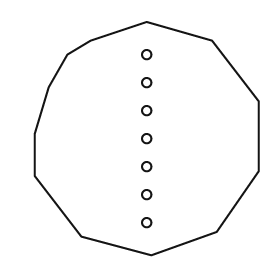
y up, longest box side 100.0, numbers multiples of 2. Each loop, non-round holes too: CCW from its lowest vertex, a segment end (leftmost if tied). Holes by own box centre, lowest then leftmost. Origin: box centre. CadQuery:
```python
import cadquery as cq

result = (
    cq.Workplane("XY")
    .moveTo(2.0, -50.0)
    .lineTo(30.0, -40.0)
    .lineTo(48.0, -14.0)
    .lineTo(48.0, 16.0)
    .lineTo(28.0, 42.0)
    .lineTo(0.0, 50.0)
    .lineTo(-24.0, 42.0)
    .lineTo(-34.0, 36.0)
    .lineTo(-42.0, 22.0)
    .lineTo(-48.0, 2.0)
    .lineTo(-48.0, -16.0)
    .lineTo(-28.0, -42.0)
    .close()
    .moveTo(0.0, -36.0)
    .circle(2.0)
    .moveTo(0.0, -24.0)
    .circle(2.0)
    .moveTo(0.0, -12.0)
    .circle(2.0)
    .moveTo(0.0, 0.0)
    .circle(2.0)
    .moveTo(0.0, 12.0)
    .circle(2.0)
    .moveTo(0.0, 24.0)
    .circle(2.0)
    .moveTo(0.0, 36.0)
    .circle(2.0)
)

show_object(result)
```